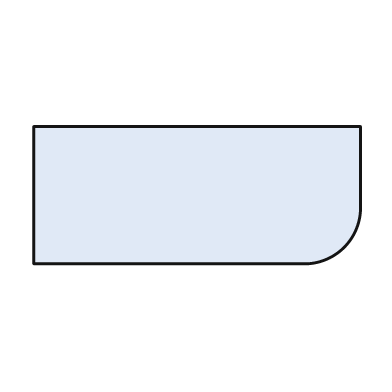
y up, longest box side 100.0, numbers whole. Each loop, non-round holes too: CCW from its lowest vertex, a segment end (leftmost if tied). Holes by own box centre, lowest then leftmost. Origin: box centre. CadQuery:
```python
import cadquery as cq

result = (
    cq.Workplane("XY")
    .moveTo(-50.0, -21.0)
    .lineTo(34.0, -21.0)
    .threePointArc((45.0, -16.0), (50.0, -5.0))
    .lineTo(50.0, 21.0)
    .lineTo(-50.0, 21.0)
    .close()
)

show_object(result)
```